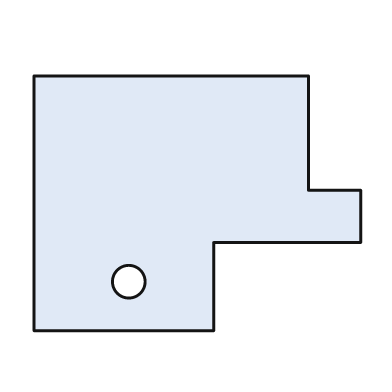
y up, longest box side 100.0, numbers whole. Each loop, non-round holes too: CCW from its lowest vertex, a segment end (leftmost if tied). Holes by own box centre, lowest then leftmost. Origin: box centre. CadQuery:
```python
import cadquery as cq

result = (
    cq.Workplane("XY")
    .moveTo(-50.0, -39.0)
    .lineTo(5.0, -39.0)
    .lineTo(5.0, -12.0)
    .lineTo(50.0, -12.0)
    .lineTo(50.0, 4.0)
    .lineTo(34.0, 4.0)
    .lineTo(34.0, 39.0)
    .lineTo(-50.0, 39.0)
    .close()
    .moveTo(-21.0, -24.0)
    .circle(5.0)
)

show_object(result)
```